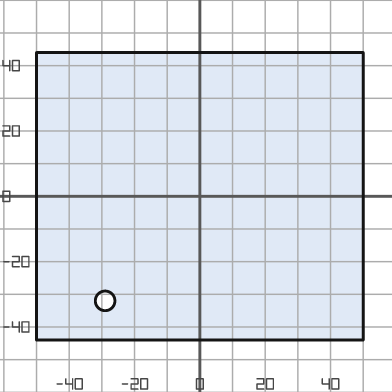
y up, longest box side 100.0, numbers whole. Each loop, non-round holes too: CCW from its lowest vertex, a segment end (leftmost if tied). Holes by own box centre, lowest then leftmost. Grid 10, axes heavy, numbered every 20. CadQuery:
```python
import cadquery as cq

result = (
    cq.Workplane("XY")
    .moveTo(-50.0, -44.0)
    .lineTo(50.0, -44.0)
    .lineTo(50.0, 44.0)
    .lineTo(-50.0, 44.0)
    .close()
    .moveTo(-29.0, -32.0)
    .circle(3.0)
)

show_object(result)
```